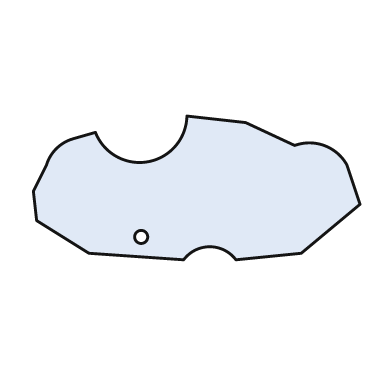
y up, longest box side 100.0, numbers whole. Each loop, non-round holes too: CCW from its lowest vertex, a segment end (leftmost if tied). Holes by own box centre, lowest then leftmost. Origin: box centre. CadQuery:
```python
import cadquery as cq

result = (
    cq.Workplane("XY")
    .moveTo(-4.0, -22.0)
    .threePointArc((4.0, -18.0), (12.0, -22.0))
    .lineTo(32.0, -20.0)
    .lineTo(50.0, -5.0)
    .lineTo(46.0, 7.0)
    .threePointArc((39.0, 13.0), (30.0, 13.0))
    .lineTo(15.0, 20.0)
    .lineTo(-3.0, 22.0)
    .threePointArc((-15.0, 8.0), (-31.0, 17.0))
    .lineTo(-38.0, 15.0)
    .threePointArc((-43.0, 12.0), (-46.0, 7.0))
    .lineTo(-50.0, -1.0)
    .lineTo(-49.0, -10.0)
    .lineTo(-33.0, -20.0)
    .close()
    .moveTo(-17.0, -15.0)
    .circle(2.0)
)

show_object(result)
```